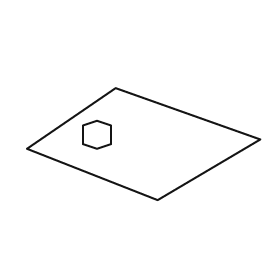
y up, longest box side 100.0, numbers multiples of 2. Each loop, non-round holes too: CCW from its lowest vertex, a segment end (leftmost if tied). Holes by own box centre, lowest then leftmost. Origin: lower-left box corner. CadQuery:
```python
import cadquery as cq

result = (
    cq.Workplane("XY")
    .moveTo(56.0, 0.0)
    .lineTo(100.0, 26.0)
    .lineTo(38.0, 48.0)
    .lineTo(0.0, 22.0)
    .close()
    .moveTo(30.0, 22.0)
    .lineTo(36.0, 24.0)
    .lineTo(36.0, 32.0)
    .lineTo(30.0, 34.0)
    .lineTo(24.0, 32.0)
    .lineTo(24.0, 24.0)
    .close()
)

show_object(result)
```